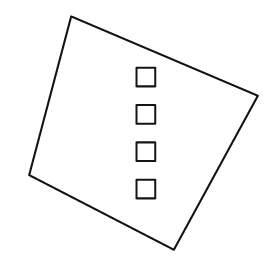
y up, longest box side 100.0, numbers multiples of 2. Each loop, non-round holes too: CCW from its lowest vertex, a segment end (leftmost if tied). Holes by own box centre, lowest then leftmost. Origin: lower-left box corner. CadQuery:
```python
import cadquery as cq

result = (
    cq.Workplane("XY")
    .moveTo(62.0, 0.0)
    .lineTo(98.0, 66.0)
    .lineTo(18.0, 100.0)
    .lineTo(0.0, 32.0)
    .close()
    .moveTo(46.0, 22.0)
    .lineTo(54.0, 22.0)
    .lineTo(54.0, 30.0)
    .lineTo(46.0, 30.0)
    .close()
    .moveTo(46.0, 38.0)
    .lineTo(54.0, 38.0)
    .lineTo(54.0, 46.0)
    .lineTo(46.0, 46.0)
    .close()
    .moveTo(46.0, 54.0)
    .lineTo(54.0, 54.0)
    .lineTo(54.0, 62.0)
    .lineTo(46.0, 62.0)
    .close()
    .moveTo(46.0, 70.0)
    .lineTo(54.0, 70.0)
    .lineTo(54.0, 78.0)
    .lineTo(46.0, 78.0)
    .close()
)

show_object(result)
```